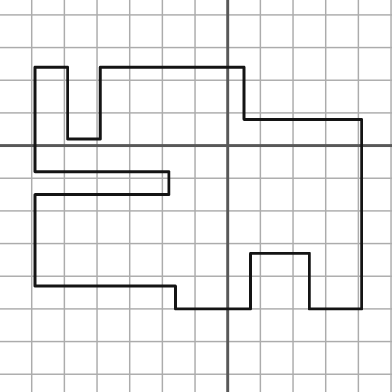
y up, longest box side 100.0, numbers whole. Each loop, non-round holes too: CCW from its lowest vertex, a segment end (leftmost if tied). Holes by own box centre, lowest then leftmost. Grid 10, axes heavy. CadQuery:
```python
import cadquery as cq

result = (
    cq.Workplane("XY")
    .moveTo(-16.0, -50.0)
    .lineTo(7.0, -50.0)
    .lineTo(7.0, -33.0)
    .lineTo(25.0, -33.0)
    .lineTo(25.0, -50.0)
    .lineTo(41.0, -50.0)
    .lineTo(41.0, 8.0)
    .lineTo(5.0, 8.0)
    .lineTo(5.0, 24.0)
    .lineTo(-39.0, 24.0)
    .lineTo(-39.0, 2.0)
    .lineTo(-49.0, 2.0)
    .lineTo(-49.0, 24.0)
    .lineTo(-59.0, 24.0)
    .lineTo(-59.0, -8.0)
    .lineTo(-18.0, -8.0)
    .lineTo(-18.0, -15.0)
    .lineTo(-59.0, -15.0)
    .lineTo(-59.0, -43.0)
    .lineTo(-16.0, -43.0)
    .close()
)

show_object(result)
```